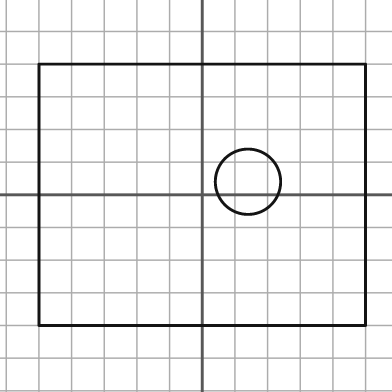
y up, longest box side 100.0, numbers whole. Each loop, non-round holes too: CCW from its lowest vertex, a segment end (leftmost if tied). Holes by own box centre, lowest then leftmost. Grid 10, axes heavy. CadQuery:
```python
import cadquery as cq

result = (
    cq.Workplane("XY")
    .moveTo(-50.0, -40.0)
    .lineTo(50.0, -40.0)
    .lineTo(50.0, 40.0)
    .lineTo(-50.0, 40.0)
    .close()
    .moveTo(14.0, 4.0)
    .circle(10.0)
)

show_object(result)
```